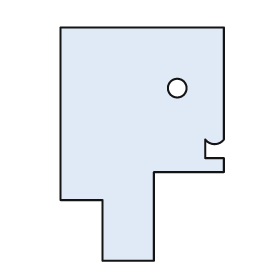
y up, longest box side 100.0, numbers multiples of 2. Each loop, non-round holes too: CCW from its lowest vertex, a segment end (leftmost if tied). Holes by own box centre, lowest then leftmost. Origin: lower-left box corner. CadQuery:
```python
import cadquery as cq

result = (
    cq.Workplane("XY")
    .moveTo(18.0, 0.0)
    .lineTo(40.0, 0.0)
    .lineTo(40.0, 38.0)
    .lineTo(70.0, 38.0)
    .lineTo(70.0, 44.0)
    .lineTo(62.0, 44.0)
    .lineTo(62.0, 52.0)
    .threePointArc((66.0, 50.0), (70.0, 52.0))
    .lineTo(70.0, 100.0)
    .lineTo(0.0, 100.0)
    .lineTo(0.0, 26.0)
    .lineTo(18.0, 26.0)
    .close()
    .moveTo(50.0, 74.0)
    .circle(4.0)
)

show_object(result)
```